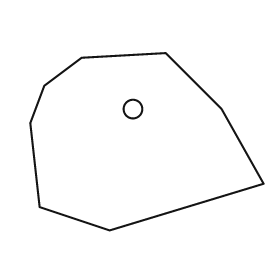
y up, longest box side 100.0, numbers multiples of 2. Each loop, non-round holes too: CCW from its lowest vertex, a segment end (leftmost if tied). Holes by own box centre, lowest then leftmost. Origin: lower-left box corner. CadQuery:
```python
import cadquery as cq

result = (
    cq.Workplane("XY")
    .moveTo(34.0, 0.0)
    .lineTo(100.0, 20.0)
    .lineTo(82.0, 52.0)
    .lineTo(58.0, 76.0)
    .lineTo(22.0, 74.0)
    .lineTo(6.0, 62.0)
    .lineTo(0.0, 46.0)
    .lineTo(4.0, 10.0)
    .close()
    .moveTo(44.0, 52.0)
    .circle(4.0)
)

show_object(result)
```